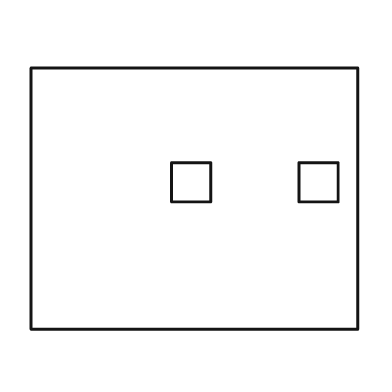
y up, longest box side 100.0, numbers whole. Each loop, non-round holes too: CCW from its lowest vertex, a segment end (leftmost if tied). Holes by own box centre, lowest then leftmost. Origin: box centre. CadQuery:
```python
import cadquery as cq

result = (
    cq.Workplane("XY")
    .moveTo(-50.0, -40.0)
    .lineTo(50.0, -40.0)
    .lineTo(50.0, 40.0)
    .lineTo(-50.0, 40.0)
    .close()
    .moveTo(-7.0, -1.0)
    .lineTo(5.0, -1.0)
    .lineTo(5.0, 11.0)
    .lineTo(-7.0, 11.0)
    .close()
    .moveTo(32.0, -1.0)
    .lineTo(44.0, -1.0)
    .lineTo(44.0, 11.0)
    .lineTo(32.0, 11.0)
    .close()
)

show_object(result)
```